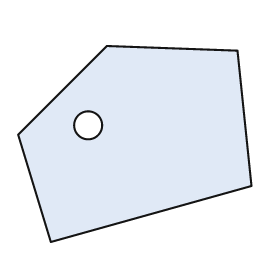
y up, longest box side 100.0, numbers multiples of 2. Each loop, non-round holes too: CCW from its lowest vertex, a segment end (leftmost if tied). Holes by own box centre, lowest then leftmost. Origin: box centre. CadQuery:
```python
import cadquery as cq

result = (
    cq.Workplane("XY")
    .moveTo(-36.0, -42.0)
    .lineTo(50.0, -18.0)
    .lineTo(44.0, 40.0)
    .lineTo(-12.0, 42.0)
    .lineTo(-50.0, 4.0)
    .close()
    .moveTo(-20.0, 8.0)
    .circle(6.0)
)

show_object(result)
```